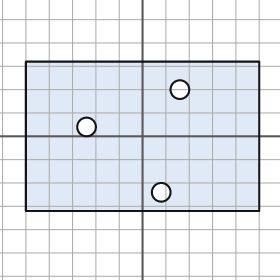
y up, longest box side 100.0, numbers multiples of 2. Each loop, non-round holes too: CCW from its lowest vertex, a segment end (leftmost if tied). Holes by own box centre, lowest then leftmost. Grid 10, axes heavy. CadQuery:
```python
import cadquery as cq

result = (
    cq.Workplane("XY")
    .moveTo(-50.0, -32.0)
    .lineTo(50.0, -32.0)
    .lineTo(50.0, 32.0)
    .lineTo(-50.0, 32.0)
    .close()
    .moveTo(8.0, -24.0)
    .circle(4.0)
    .moveTo(-24.0, 4.0)
    .circle(4.0)
    .moveTo(16.0, 20.0)
    .circle(4.0)
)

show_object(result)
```